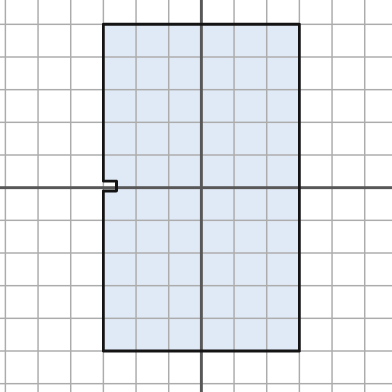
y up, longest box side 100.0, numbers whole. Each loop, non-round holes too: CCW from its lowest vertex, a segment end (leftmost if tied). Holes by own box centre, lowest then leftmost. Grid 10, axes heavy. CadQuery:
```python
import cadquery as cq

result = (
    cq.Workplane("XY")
    .moveTo(-30.0, -50.0)
    .lineTo(30.0, -50.0)
    .lineTo(30.0, 50.0)
    .lineTo(-30.0, 50.0)
    .lineTo(-30.0, 2.0)
    .lineTo(-26.0, 2.0)
    .lineTo(-26.0, -1.0)
    .lineTo(-30.0, -1.0)
    .close()
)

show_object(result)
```